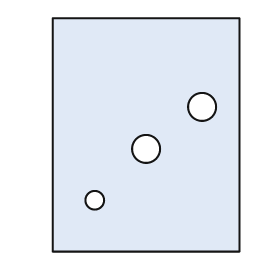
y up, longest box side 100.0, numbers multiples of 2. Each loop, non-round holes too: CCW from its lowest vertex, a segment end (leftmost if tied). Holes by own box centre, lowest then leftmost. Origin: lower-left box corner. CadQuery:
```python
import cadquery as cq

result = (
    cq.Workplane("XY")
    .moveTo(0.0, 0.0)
    .lineTo(80.0, 0.0)
    .lineTo(80.0, 100.0)
    .lineTo(0.0, 100.0)
    .close()
    .moveTo(18.0, 22.0)
    .circle(4.0)
    .moveTo(40.0, 44.0)
    .circle(6.0)
    .moveTo(64.0, 62.0)
    .circle(6.0)
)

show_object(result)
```